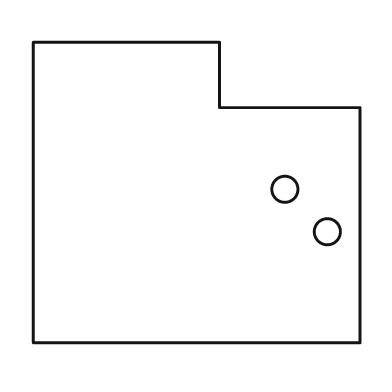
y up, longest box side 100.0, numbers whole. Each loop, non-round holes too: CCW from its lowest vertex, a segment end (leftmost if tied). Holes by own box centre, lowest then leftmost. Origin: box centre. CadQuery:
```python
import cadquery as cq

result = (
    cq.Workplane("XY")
    .moveTo(-50.0, -46.0)
    .lineTo(50.0, -46.0)
    .lineTo(50.0, 26.0)
    .lineTo(7.0, 26.0)
    .lineTo(7.0, 46.0)
    .lineTo(-50.0, 46.0)
    .close()
    .moveTo(40.0, -12.0)
    .circle(4.0)
    .moveTo(27.0, 1.0)
    .circle(4.0)
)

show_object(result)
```